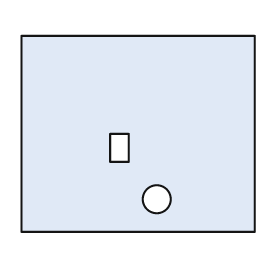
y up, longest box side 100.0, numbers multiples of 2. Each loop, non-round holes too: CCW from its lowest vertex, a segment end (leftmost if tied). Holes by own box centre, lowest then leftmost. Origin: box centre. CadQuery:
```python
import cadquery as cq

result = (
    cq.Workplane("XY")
    .moveTo(-50.0, -42.0)
    .lineTo(50.0, -42.0)
    .lineTo(50.0, 42.0)
    .lineTo(-50.0, 42.0)
    .close()
    .moveTo(8.0, -28.0)
    .circle(6.0)
    .moveTo(-12.0, -12.0)
    .lineTo(-4.0, -12.0)
    .lineTo(-4.0, 0.0)
    .lineTo(-12.0, 0.0)
    .close()
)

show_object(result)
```